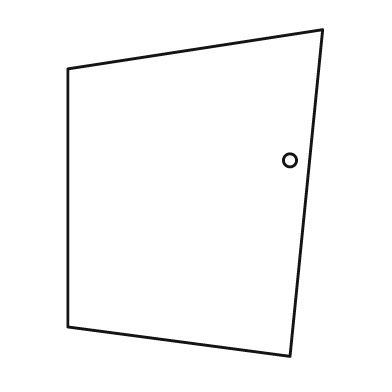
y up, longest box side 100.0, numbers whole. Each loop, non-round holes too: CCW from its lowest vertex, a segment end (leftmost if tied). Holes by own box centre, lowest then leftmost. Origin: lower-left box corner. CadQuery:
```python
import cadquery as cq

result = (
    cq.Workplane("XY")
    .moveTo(68.0, 0.0)
    .lineTo(78.0, 100.0)
    .lineTo(0.0, 88.0)
    .lineTo(0.0, 9.0)
    .close()
    .moveTo(68.0, 60.0)
    .circle(2.0)
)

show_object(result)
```